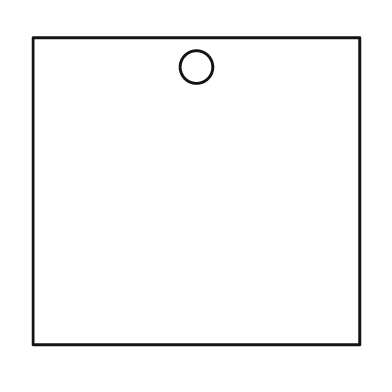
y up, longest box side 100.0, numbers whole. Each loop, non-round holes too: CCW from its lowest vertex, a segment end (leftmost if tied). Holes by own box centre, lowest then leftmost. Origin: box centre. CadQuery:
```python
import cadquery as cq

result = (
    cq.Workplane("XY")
    .moveTo(-50.0, -47.0)
    .lineTo(50.0, -47.0)
    .lineTo(50.0, 47.0)
    .lineTo(-50.0, 47.0)
    .close()
    .moveTo(0.0, 38.0)
    .circle(5.0)
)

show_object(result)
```